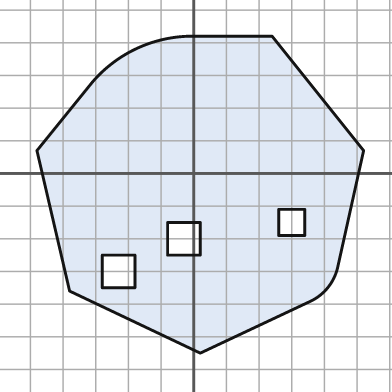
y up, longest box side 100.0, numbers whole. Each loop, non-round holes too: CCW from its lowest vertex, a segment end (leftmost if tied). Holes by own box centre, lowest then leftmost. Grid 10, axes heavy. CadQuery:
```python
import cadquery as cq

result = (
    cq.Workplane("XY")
    .moveTo(2.0, -55.0)
    .lineTo(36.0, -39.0)
    .threePointArc((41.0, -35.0), (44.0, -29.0))
    .lineTo(52.0, 7.0)
    .lineTo(24.0, 42.0)
    .lineTo(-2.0, 42.0)
    .threePointArc((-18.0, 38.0), (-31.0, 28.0))
    .lineTo(-48.0, 7.0)
    .lineTo(-38.0, -36.0)
    .close()
    .moveTo(-28.0, -35.0)
    .lineTo(-18.0, -35.0)
    .lineTo(-18.0, -25.0)
    .lineTo(-28.0, -25.0)
    .close()
    .moveTo(-8.0, -25.0)
    .lineTo(2.0, -25.0)
    .lineTo(2.0, -15.0)
    .lineTo(-8.0, -15.0)
    .close()
    .moveTo(26.0, -19.0)
    .lineTo(34.0, -19.0)
    .lineTo(34.0, -11.0)
    .lineTo(26.0, -11.0)
    .close()
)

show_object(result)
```